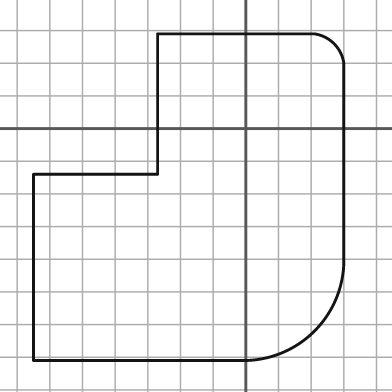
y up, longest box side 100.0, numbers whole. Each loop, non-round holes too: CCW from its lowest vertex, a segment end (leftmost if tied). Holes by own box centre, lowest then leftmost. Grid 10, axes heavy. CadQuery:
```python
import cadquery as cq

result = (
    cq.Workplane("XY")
    .moveTo(-65.0, -71.0)
    .lineTo(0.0, -71.0)
    .threePointArc((21.0, -62.0), (30.0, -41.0))
    .lineTo(30.0, 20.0)
    .threePointArc((27.0, 26.0), (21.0, 29.0))
    .lineTo(-27.0, 29.0)
    .lineTo(-27.0, -14.0)
    .lineTo(-65.0, -14.0)
    .close()
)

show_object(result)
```